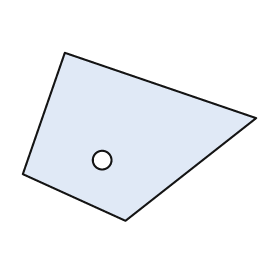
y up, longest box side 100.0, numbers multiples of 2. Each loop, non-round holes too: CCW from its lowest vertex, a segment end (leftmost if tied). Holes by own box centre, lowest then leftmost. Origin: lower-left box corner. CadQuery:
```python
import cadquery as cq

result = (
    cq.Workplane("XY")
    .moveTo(44.0, 0.0)
    .lineTo(100.0, 44.0)
    .lineTo(18.0, 72.0)
    .lineTo(0.0, 20.0)
    .close()
    .moveTo(34.0, 26.0)
    .circle(4.0)
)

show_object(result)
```